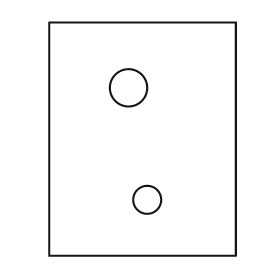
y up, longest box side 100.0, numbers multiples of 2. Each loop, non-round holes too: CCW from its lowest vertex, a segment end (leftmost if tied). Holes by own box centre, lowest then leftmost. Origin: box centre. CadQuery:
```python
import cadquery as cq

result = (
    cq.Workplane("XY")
    .moveTo(-40.0, -50.0)
    .lineTo(40.0, -50.0)
    .lineTo(40.0, 50.0)
    .lineTo(-40.0, 50.0)
    .close()
    .moveTo(2.0, -26.0)
    .circle(6.0)
    .moveTo(-6.0, 22.0)
    .circle(8.0)
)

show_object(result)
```